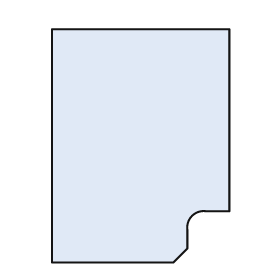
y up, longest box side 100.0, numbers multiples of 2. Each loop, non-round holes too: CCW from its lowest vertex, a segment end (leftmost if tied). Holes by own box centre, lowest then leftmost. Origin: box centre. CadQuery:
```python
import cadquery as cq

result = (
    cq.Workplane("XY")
    .moveTo(-38.0, -50.0)
    .lineTo(14.0, -50.0)
    .lineTo(20.0, -44.0)
    .lineTo(20.0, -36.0)
    .threePointArc((22.0, -30.0), (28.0, -28.0))
    .lineTo(38.0, -28.0)
    .lineTo(38.0, 50.0)
    .lineTo(-38.0, 50.0)
    .close()
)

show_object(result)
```